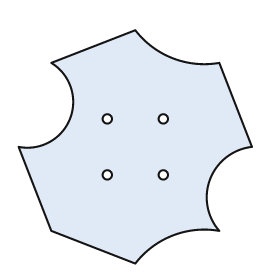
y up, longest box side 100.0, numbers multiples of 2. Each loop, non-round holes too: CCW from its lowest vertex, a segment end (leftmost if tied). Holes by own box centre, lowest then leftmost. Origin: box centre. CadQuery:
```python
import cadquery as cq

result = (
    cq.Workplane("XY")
    .moveTo(0.0, -50.0)
    .threePointArc((16.0, -38.0), (36.0, -36.0))
    .threePointArc((32.0, -14.0), (50.0, 0.0))
    .lineTo(36.0, 36.0)
    .threePointArc((16.0, 38.0), (0.0, 50.0))
    .lineTo(-36.0, 36.0)
    .threePointArc((-28.0, 12.0), (-50.0, 0.0))
    .lineTo(-36.0, -36.0)
    .close()
    .moveTo(-12.0, -12.0)
    .circle(2.0)
    .moveTo(12.0, -12.0)
    .circle(2.0)
    .moveTo(-12.0, 12.0)
    .circle(2.0)
    .moveTo(12.0, 12.0)
    .circle(2.0)
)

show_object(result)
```